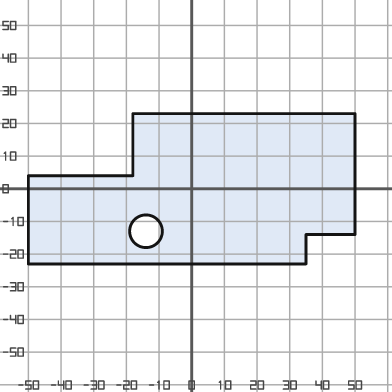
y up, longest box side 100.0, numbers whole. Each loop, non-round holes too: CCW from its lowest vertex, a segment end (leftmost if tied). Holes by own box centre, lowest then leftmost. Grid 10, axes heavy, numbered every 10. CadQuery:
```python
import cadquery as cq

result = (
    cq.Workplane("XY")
    .moveTo(-50.0, -23.0)
    .lineTo(35.0, -23.0)
    .lineTo(35.0, -14.0)
    .lineTo(50.0, -14.0)
    .lineTo(50.0, 23.0)
    .lineTo(-18.0, 23.0)
    .lineTo(-18.0, 4.0)
    .lineTo(-50.0, 4.0)
    .close()
    .moveTo(-14.0, -13.0)
    .circle(5.0)
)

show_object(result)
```